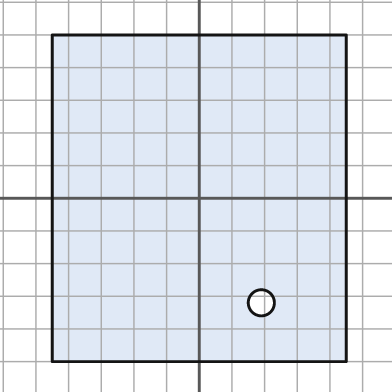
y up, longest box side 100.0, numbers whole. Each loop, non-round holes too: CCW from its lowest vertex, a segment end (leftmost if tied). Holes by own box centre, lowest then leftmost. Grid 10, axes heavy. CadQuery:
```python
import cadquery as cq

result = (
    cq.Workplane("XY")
    .moveTo(-45.0, -50.0)
    .lineTo(45.0, -50.0)
    .lineTo(45.0, 50.0)
    .lineTo(-45.0, 50.0)
    .close()
    .moveTo(19.0, -32.0)
    .circle(4.0)
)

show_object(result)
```